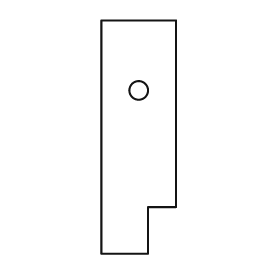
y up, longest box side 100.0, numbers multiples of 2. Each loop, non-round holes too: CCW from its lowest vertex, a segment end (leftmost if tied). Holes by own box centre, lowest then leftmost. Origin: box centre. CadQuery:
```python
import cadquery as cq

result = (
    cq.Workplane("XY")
    .moveTo(-16.0, -50.0)
    .lineTo(4.0, -50.0)
    .lineTo(4.0, -30.0)
    .lineTo(16.0, -30.0)
    .lineTo(16.0, 50.0)
    .lineTo(-16.0, 50.0)
    .close()
    .moveTo(0.0, 20.0)
    .circle(4.0)
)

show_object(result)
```